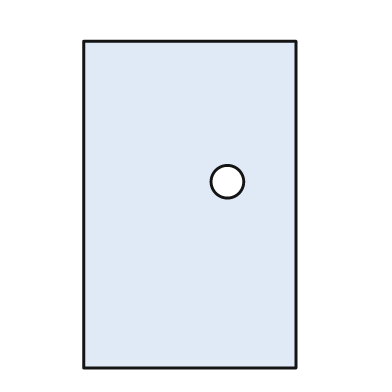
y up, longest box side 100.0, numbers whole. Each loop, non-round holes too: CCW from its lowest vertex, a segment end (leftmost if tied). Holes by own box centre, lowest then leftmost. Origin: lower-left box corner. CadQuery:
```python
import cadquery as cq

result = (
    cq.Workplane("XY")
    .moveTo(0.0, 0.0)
    .lineTo(65.0, 0.0)
    .lineTo(65.0, 100.0)
    .lineTo(0.0, 100.0)
    .close()
    .moveTo(44.0, 57.0)
    .circle(5.0)
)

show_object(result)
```